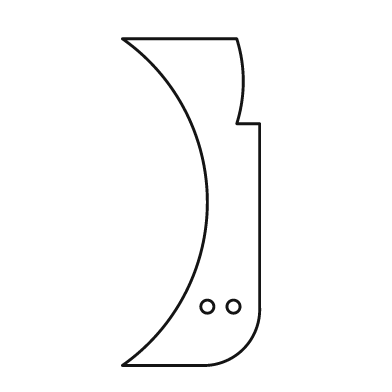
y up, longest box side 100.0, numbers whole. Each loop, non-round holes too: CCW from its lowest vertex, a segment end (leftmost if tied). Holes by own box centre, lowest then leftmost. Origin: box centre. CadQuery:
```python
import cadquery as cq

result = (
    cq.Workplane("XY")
    .moveTo(-21.0, -50.0)
    .lineTo(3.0, -50.0)
    .threePointArc((16.0, -45.0), (21.0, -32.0))
    .lineTo(21.0, 24.0)
    .lineTo(14.0, 24.0)
    .threePointArc((16.0, 37.0), (14.0, 50.0))
    .lineTo(-21.0, 50.0)
    .threePointArc((5.0, 0.0), (-21.0, -50.0))
    .close()
    .moveTo(5.0, -32.0)
    .circle(2.0)
    .moveTo(13.0, -32.0)
    .circle(2.0)
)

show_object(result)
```